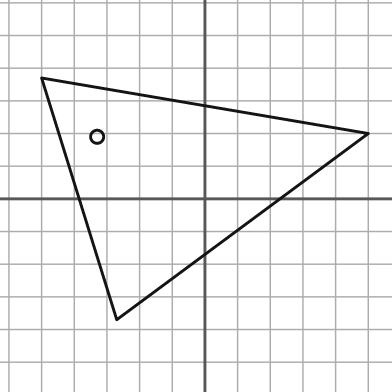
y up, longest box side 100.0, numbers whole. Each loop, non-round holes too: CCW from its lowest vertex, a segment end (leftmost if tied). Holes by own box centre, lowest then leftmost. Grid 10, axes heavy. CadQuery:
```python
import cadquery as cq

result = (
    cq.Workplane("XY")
    .moveTo(-27.0, -37.0)
    .lineTo(50.0, 20.0)
    .lineTo(-50.0, 37.0)
    .close()
    .moveTo(-33.0, 19.0)
    .circle(2.0)
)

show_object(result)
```